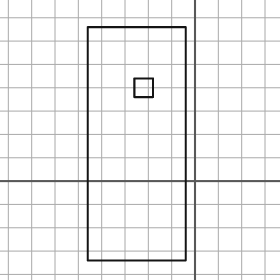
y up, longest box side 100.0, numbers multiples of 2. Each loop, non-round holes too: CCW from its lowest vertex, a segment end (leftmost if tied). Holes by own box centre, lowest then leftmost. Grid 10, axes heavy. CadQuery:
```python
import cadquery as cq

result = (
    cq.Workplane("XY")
    .moveTo(-46.0, -34.0)
    .lineTo(-4.0, -34.0)
    .lineTo(-4.0, 66.0)
    .lineTo(-46.0, 66.0)
    .close()
    .moveTo(-26.0, 36.0)
    .lineTo(-18.0, 36.0)
    .lineTo(-18.0, 44.0)
    .lineTo(-26.0, 44.0)
    .close()
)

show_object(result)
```